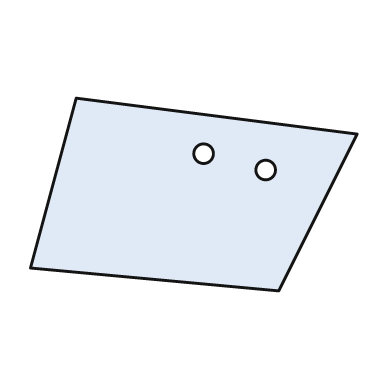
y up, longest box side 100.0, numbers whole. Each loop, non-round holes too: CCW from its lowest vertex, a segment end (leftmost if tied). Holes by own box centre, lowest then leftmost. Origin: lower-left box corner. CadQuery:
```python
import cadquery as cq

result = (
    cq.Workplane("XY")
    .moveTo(76.0, 0.0)
    .lineTo(100.0, 48.0)
    .lineTo(14.0, 59.0)
    .lineTo(0.0, 7.0)
    .close()
    .moveTo(72.0, 37.0)
    .circle(3.0)
    .moveTo(53.0, 42.0)
    .circle(3.0)
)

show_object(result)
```